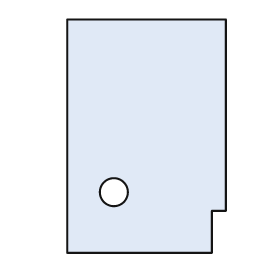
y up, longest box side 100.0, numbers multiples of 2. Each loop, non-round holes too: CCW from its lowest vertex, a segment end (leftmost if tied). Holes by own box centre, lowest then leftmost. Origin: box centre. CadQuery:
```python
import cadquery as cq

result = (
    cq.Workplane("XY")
    .moveTo(-34.0, -50.0)
    .lineTo(28.0, -50.0)
    .lineTo(28.0, -32.0)
    .lineTo(34.0, -32.0)
    .lineTo(34.0, 50.0)
    .lineTo(-34.0, 50.0)
    .close()
    .moveTo(-14.0, -24.0)
    .circle(6.0)
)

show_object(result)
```